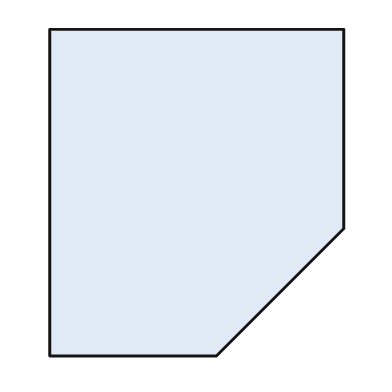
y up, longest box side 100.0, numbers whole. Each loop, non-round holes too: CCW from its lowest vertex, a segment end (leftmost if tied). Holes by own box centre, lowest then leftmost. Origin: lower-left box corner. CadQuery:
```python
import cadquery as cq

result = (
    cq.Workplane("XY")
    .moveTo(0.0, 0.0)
    .lineTo(51.0, 0.0)
    .lineTo(90.0, 39.0)
    .lineTo(90.0, 100.0)
    .lineTo(0.0, 100.0)
    .close()
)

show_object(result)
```